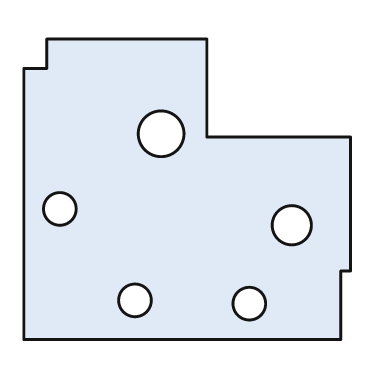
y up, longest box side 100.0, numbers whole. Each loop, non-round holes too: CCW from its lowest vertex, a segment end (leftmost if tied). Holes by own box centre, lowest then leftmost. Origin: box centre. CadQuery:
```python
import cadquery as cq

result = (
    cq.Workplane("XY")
    .moveTo(-50.0, -46.0)
    .lineTo(47.0, -46.0)
    .lineTo(47.0, -25.0)
    .lineTo(50.0, -25.0)
    .lineTo(50.0, 16.0)
    .lineTo(6.0, 16.0)
    .lineTo(6.0, 46.0)
    .lineTo(-43.0, 46.0)
    .lineTo(-43.0, 37.0)
    .lineTo(-50.0, 37.0)
    .close()
    .moveTo(19.0, -35.0)
    .circle(5.0)
    .moveTo(-16.0, -34.0)
    .circle(5.0)
    .moveTo(32.0, -11.0)
    .circle(6.0)
    .moveTo(-39.0, -6.0)
    .circle(5.0)
    .moveTo(-8.0, 17.0)
    .circle(7.0)
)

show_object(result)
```